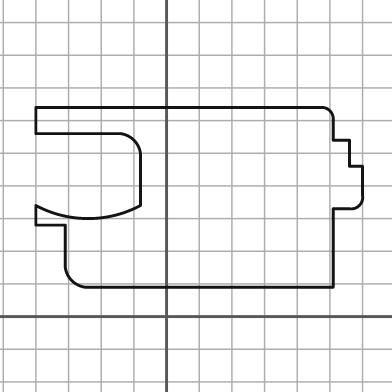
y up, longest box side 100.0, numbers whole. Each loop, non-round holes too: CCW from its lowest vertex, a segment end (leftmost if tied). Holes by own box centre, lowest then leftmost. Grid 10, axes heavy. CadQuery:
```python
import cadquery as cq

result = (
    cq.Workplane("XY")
    .moveTo(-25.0, 9.0)
    .lineTo(51.0, 9.0)
    .lineTo(51.0, 33.0)
    .lineTo(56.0, 33.0)
    .threePointArc((59.0, 34.0), (60.0, 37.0))
    .lineTo(60.0, 46.0)
    .lineTo(56.0, 46.0)
    .lineTo(56.0, 54.0)
    .lineTo(51.0, 54.0)
    .lineTo(51.0, 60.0)
    .threePointArc((50.0, 63.0), (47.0, 64.0))
    .lineTo(-40.0, 64.0)
    .lineTo(-40.0, 56.0)
    .lineTo(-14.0, 56.0)
    .threePointArc((-10.0, 54.0), (-8.0, 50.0))
    .lineTo(-8.0, 34.0)
    .threePointArc((-24.0, 30.0), (-40.0, 34.0))
    .lineTo(-40.0, 28.0)
    .lineTo(-31.0, 28.0)
    .lineTo(-31.0, 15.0)
    .threePointArc((-29.0, 11.0), (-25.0, 9.0))
    .close()
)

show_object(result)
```